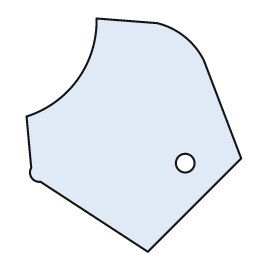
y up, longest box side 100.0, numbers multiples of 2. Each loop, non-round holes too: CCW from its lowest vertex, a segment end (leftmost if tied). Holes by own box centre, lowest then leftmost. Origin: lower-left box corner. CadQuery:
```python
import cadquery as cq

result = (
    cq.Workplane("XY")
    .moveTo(52.0, 0.0)
    .lineTo(92.0, 40.0)
    .lineTo(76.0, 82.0)
    .threePointArc((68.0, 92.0), (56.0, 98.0))
    .lineTo(30.0, 100.0)
    .threePointArc((22.0, 74.0), (0.0, 58.0))
    .lineTo(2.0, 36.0)
    .threePointArc((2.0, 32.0), (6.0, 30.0))
    .close()
    .moveTo(68.0, 38.0)
    .circle(4.0)
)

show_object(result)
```